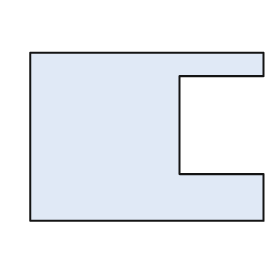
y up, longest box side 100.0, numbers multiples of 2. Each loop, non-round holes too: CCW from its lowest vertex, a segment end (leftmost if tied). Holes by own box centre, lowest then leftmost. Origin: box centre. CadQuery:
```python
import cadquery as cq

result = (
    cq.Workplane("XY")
    .moveTo(-50.0, -36.0)
    .lineTo(50.0, -36.0)
    .lineTo(50.0, -16.0)
    .lineTo(14.0, -16.0)
    .lineTo(14.0, 26.0)
    .lineTo(50.0, 26.0)
    .lineTo(50.0, 36.0)
    .lineTo(-50.0, 36.0)
    .close()
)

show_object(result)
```